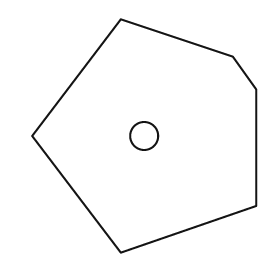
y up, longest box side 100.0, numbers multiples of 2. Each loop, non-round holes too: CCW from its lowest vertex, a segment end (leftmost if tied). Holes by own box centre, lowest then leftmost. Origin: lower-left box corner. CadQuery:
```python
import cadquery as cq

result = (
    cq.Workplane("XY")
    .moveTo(38.0, 0.0)
    .lineTo(96.0, 20.0)
    .lineTo(96.0, 70.0)
    .lineTo(86.0, 84.0)
    .lineTo(38.0, 100.0)
    .lineTo(0.0, 50.0)
    .close()
    .moveTo(48.0, 50.0)
    .circle(6.0)
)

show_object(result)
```